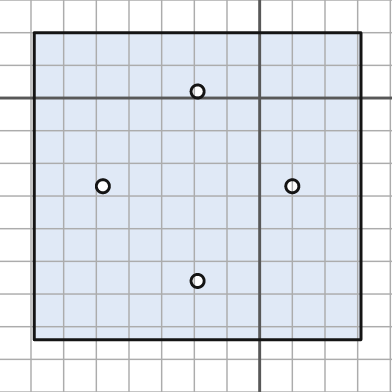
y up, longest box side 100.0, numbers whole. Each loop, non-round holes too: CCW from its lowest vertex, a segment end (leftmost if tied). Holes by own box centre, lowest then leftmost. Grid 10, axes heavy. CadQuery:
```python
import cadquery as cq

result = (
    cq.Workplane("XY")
    .moveTo(-69.0, -74.0)
    .lineTo(31.0, -74.0)
    .lineTo(31.0, 20.0)
    .lineTo(-69.0, 20.0)
    .close()
    .moveTo(-19.0, -56.0)
    .circle(2.0)
    .moveTo(-48.0, -27.0)
    .circle(2.0)
    .moveTo(10.0, -27.0)
    .circle(2.0)
    .moveTo(-19.0, 2.0)
    .circle(2.0)
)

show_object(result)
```